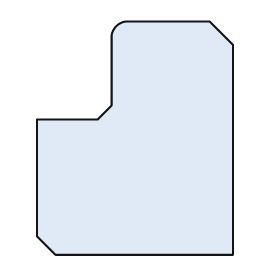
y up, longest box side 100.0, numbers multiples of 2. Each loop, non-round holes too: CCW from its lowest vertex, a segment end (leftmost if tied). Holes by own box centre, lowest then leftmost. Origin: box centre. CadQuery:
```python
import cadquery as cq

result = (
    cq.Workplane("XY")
    .moveTo(-34.0, -50.0)
    .lineTo(42.0, -50.0)
    .lineTo(42.0, 40.0)
    .lineTo(32.0, 50.0)
    .lineTo(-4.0, 50.0)
    .threePointArc((-8.0, 48.0), (-10.0, 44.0))
    .lineTo(-10.0, 14.0)
    .lineTo(-16.0, 8.0)
    .lineTo(-42.0, 8.0)
    .lineTo(-42.0, -42.0)
    .close()
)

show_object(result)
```